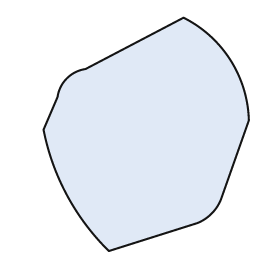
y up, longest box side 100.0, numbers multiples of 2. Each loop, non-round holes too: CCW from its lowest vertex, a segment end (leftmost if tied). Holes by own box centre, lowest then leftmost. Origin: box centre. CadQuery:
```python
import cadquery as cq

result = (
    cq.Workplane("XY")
    .moveTo(-16.0, -50.0)
    .lineTo(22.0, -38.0)
    .threePointArc((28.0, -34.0), (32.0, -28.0))
    .lineTo(44.0, 6.0)
    .threePointArc((36.0, 32.0), (16.0, 50.0))
    .lineTo(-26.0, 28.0)
    .threePointArc((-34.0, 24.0), (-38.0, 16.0))
    .lineTo(-44.0, 2.0)
    .threePointArc((-34.0, -26.0), (-16.0, -50.0))
    .close()
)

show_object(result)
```